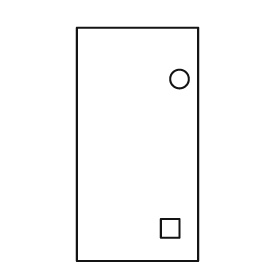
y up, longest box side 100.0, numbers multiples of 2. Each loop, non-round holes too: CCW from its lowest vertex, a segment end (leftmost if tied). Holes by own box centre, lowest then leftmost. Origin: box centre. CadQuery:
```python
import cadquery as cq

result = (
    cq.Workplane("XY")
    .moveTo(-26.0, -50.0)
    .lineTo(26.0, -50.0)
    .lineTo(26.0, 50.0)
    .lineTo(-26.0, 50.0)
    .close()
    .moveTo(10.0, -40.0)
    .lineTo(18.0, -40.0)
    .lineTo(18.0, -32.0)
    .lineTo(10.0, -32.0)
    .close()
    .moveTo(18.0, 28.0)
    .circle(4.0)
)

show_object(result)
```